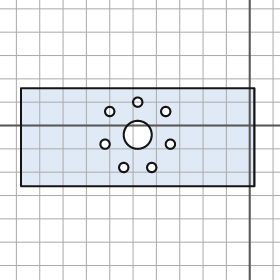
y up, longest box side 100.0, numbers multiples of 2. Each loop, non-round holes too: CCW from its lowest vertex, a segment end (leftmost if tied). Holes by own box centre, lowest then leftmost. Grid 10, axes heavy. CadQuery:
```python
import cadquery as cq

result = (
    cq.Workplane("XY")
    .moveTo(-98.0, -26.0)
    .lineTo(2.0, -26.0)
    .lineTo(2.0, 16.0)
    .lineTo(-98.0, 16.0)
    .close()
    .moveTo(-54.0, -18.0)
    .circle(2.0)
    .moveTo(-42.0, -18.0)
    .circle(2.0)
    .moveTo(-62.0, -8.0)
    .circle(2.0)
    .moveTo(-34.0, -8.0)
    .circle(2.0)
    .moveTo(-48.0, -4.0)
    .circle(6.0)
    .moveTo(-60.0, 6.0)
    .circle(2.0)
    .moveTo(-36.0, 6.0)
    .circle(2.0)
    .moveTo(-48.0, 10.0)
    .circle(2.0)
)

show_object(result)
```